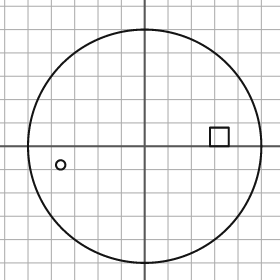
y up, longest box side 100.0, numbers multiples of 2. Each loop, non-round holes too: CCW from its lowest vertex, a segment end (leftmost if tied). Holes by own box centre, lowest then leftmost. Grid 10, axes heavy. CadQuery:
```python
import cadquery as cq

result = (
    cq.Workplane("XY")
    .moveTo(0.0, 0.0)
    .circle(50.0)
    .moveTo(-36.0, -8.0)
    .circle(2.0)
    .moveTo(28.0, 0.0)
    .lineTo(36.0, 0.0)
    .lineTo(36.0, 8.0)
    .lineTo(28.0, 8.0)
    .close()
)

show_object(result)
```